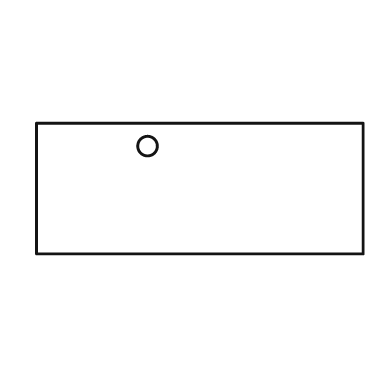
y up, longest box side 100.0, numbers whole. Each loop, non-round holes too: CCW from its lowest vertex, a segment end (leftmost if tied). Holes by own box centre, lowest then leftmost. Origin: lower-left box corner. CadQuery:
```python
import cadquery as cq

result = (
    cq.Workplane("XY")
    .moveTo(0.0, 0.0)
    .lineTo(100.0, 0.0)
    .lineTo(100.0, 40.0)
    .lineTo(0.0, 40.0)
    .close()
    .moveTo(34.0, 33.0)
    .circle(3.0)
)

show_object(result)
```